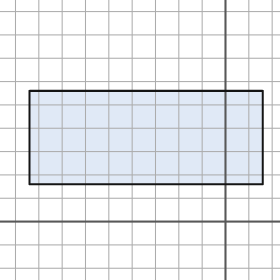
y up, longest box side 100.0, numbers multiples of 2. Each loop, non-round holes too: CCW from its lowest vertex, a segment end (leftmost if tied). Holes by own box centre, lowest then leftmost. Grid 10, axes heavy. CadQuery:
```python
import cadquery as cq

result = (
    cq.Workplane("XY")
    .moveTo(-84.0, 16.0)
    .lineTo(16.0, 16.0)
    .lineTo(16.0, 56.0)
    .lineTo(-84.0, 56.0)
    .close()
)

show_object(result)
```